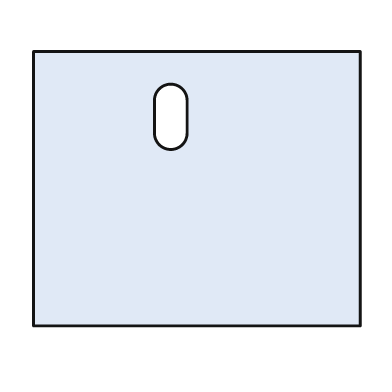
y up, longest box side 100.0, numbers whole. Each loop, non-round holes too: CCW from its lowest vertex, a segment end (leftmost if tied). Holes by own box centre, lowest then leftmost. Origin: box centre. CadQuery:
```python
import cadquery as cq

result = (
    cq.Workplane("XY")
    .moveTo(-50.0, -42.0)
    .lineTo(50.0, -42.0)
    .lineTo(50.0, 42.0)
    .lineTo(-50.0, 42.0)
    .close()
    .moveTo(-13.0, 17.0)
    .threePointArc((-8.0, 12.0), (-3.0, 17.0))
    .lineTo(-3.0, 27.0)
    .threePointArc((-8.0, 32.0), (-13.0, 27.0))
    .close()
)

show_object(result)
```